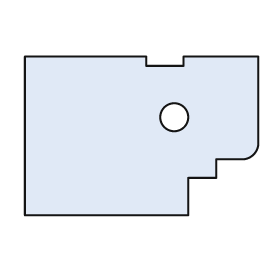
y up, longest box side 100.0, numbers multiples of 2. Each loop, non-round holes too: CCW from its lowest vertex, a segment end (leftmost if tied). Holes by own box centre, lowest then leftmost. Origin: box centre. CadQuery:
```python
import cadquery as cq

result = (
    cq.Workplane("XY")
    .moveTo(-50.0, -34.0)
    .lineTo(20.0, -34.0)
    .lineTo(20.0, -18.0)
    .lineTo(32.0, -18.0)
    .lineTo(32.0, -10.0)
    .lineTo(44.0, -10.0)
    .threePointArc((48.0, -8.0), (50.0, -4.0))
    .lineTo(50.0, 34.0)
    .lineTo(18.0, 34.0)
    .lineTo(18.0, 30.0)
    .lineTo(2.0, 30.0)
    .lineTo(2.0, 34.0)
    .lineTo(-50.0, 34.0)
    .close()
    .moveTo(14.0, 8.0)
    .circle(6.0)
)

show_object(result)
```